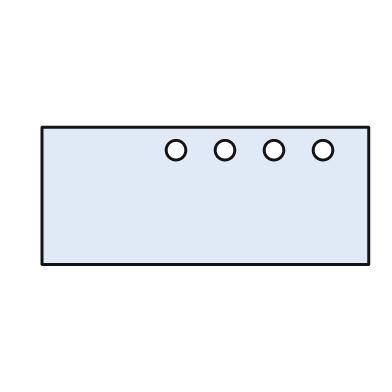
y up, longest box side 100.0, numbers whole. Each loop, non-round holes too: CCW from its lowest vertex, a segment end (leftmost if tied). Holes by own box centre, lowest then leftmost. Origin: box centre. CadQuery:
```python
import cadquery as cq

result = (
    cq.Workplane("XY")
    .moveTo(-50.0, -21.0)
    .lineTo(50.0, -21.0)
    .lineTo(50.0, 21.0)
    .lineTo(-50.0, 21.0)
    .close()
    .moveTo(-9.0, 14.0)
    .circle(3.0)
    .moveTo(6.0, 14.0)
    .circle(3.0)
    .moveTo(21.0, 14.0)
    .circle(3.0)
    .moveTo(36.0, 14.0)
    .circle(3.0)
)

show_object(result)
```